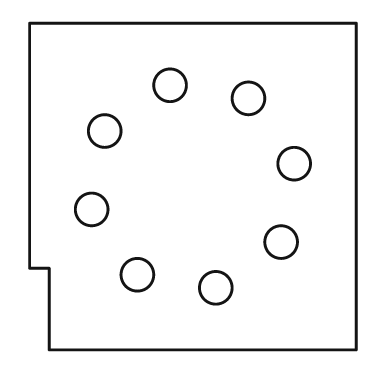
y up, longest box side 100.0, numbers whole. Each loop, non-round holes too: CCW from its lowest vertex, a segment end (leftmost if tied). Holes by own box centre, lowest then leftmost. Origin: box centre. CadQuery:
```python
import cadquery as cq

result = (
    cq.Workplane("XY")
    .moveTo(-44.0, -50.0)
    .lineTo(50.0, -50.0)
    .lineTo(50.0, 50.0)
    .lineTo(-50.0, 50.0)
    .lineTo(-50.0, -25.0)
    .lineTo(-44.0, -25.0)
    .close()
    .moveTo(7.0, -31.0)
    .circle(5.0)
    .moveTo(-17.0, -27.0)
    .circle(5.0)
    .moveTo(27.0, -17.0)
    .circle(5.0)
    .moveTo(-31.0, -7.0)
    .circle(5.0)
    .moveTo(31.0, 7.0)
    .circle(5.0)
    .moveTo(-27.0, 17.0)
    .circle(5.0)
    .moveTo(17.0, 27.0)
    .circle(5.0)
    .moveTo(-7.0, 31.0)
    .circle(5.0)
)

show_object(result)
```